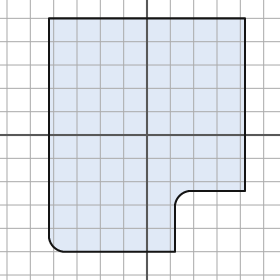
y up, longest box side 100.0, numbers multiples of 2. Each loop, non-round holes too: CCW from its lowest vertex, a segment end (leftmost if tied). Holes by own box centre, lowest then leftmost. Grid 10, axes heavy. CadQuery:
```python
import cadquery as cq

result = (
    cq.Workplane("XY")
    .moveTo(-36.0, -50.0)
    .lineTo(12.0, -50.0)
    .lineTo(12.0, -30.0)
    .threePointArc((14.0, -26.0), (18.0, -24.0))
    .lineTo(42.0, -24.0)
    .lineTo(42.0, 50.0)
    .lineTo(-42.0, 50.0)
    .lineTo(-42.0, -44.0)
    .threePointArc((-40.0, -48.0), (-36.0, -50.0))
    .close()
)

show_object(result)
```